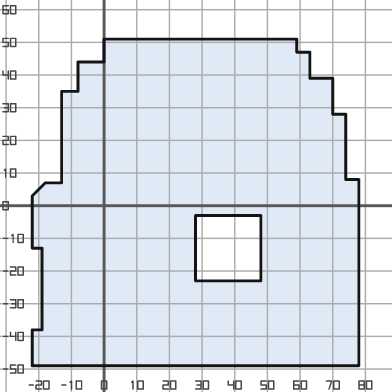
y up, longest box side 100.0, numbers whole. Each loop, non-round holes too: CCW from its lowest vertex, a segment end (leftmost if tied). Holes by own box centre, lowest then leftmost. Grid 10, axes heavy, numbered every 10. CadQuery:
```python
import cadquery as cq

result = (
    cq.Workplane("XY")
    .moveTo(-22.0, -49.0)
    .lineTo(78.0, -49.0)
    .lineTo(78.0, 8.0)
    .lineTo(74.0, 8.0)
    .lineTo(74.0, 28.0)
    .lineTo(70.0, 28.0)
    .lineTo(70.0, 39.0)
    .lineTo(63.0, 39.0)
    .lineTo(63.0, 47.0)
    .lineTo(59.0, 47.0)
    .lineTo(59.0, 51.0)
    .lineTo(0.0, 51.0)
    .lineTo(0.0, 44.0)
    .lineTo(-8.0, 44.0)
    .lineTo(-8.0, 35.0)
    .lineTo(-13.0, 35.0)
    .lineTo(-13.0, 7.0)
    .lineTo(-18.0, 7.0)
    .lineTo(-22.0, 3.0)
    .lineTo(-22.0, -13.0)
    .lineTo(-19.0, -13.0)
    .lineTo(-19.0, -38.0)
    .lineTo(-22.0, -38.0)
    .close()
    .moveTo(28.0, -23.0)
    .lineTo(48.0, -23.0)
    .lineTo(48.0, -3.0)
    .lineTo(28.0, -3.0)
    .close()
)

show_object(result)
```